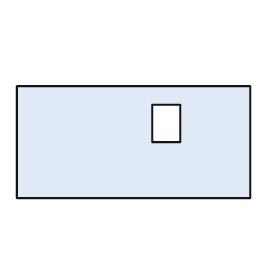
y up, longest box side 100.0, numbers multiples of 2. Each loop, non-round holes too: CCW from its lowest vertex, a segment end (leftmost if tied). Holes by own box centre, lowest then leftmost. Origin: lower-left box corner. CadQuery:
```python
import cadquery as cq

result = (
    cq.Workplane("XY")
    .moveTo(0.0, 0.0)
    .lineTo(100.0, 0.0)
    .lineTo(100.0, 48.0)
    .lineTo(0.0, 48.0)
    .close()
    .moveTo(58.0, 24.0)
    .lineTo(70.0, 24.0)
    .lineTo(70.0, 40.0)
    .lineTo(58.0, 40.0)
    .close()
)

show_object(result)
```